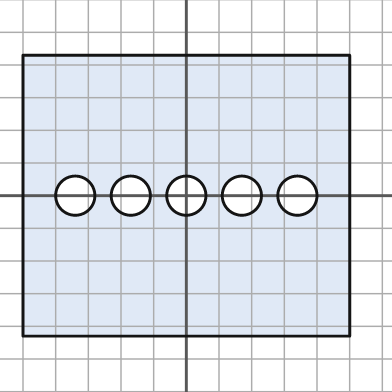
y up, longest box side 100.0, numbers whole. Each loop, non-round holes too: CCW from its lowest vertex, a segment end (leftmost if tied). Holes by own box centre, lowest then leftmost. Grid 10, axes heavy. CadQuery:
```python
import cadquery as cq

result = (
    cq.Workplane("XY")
    .moveTo(-50.0, -43.0)
    .lineTo(50.0, -43.0)
    .lineTo(50.0, 43.0)
    .lineTo(-50.0, 43.0)
    .close()
    .moveTo(-34.0, 0.0)
    .circle(6.0)
    .moveTo(-17.0, 0.0)
    .circle(6.0)
    .moveTo(0.0, 0.0)
    .circle(6.0)
    .moveTo(17.0, 0.0)
    .circle(6.0)
    .moveTo(34.0, 0.0)
    .circle(6.0)
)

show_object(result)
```